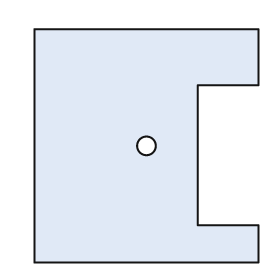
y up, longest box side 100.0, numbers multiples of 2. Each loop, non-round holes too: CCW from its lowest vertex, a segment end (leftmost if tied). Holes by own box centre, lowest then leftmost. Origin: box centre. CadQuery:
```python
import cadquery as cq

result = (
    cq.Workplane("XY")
    .moveTo(-48.0, -50.0)
    .lineTo(48.0, -50.0)
    .lineTo(48.0, -34.0)
    .lineTo(22.0, -34.0)
    .lineTo(22.0, 26.0)
    .lineTo(48.0, 26.0)
    .lineTo(48.0, 50.0)
    .lineTo(-48.0, 50.0)
    .close()
    .moveTo(0.0, 0.0)
    .circle(4.0)
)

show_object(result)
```